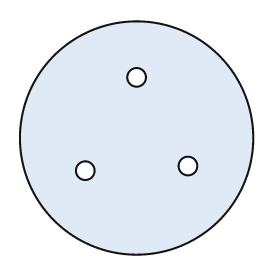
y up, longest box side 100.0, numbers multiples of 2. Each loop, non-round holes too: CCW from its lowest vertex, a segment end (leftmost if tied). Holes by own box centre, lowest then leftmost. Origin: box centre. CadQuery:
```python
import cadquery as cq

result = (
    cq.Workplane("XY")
    .moveTo(0.0, 0.0)
    .circle(50.0)
    .moveTo(-22.0, -14.0)
    .circle(4.0)
    .moveTo(22.0, -12.0)
    .circle(4.0)
    .moveTo(0.0, 26.0)
    .circle(4.0)
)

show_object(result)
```